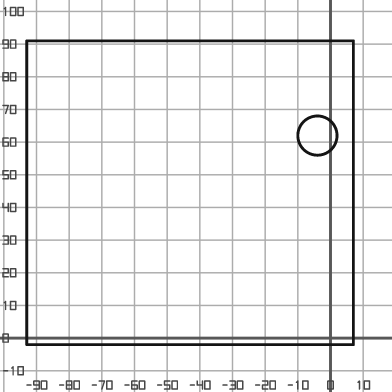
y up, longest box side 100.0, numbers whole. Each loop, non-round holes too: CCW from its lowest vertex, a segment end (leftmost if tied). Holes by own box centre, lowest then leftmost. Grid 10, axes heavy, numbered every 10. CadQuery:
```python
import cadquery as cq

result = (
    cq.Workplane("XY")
    .moveTo(-93.0, -2.0)
    .lineTo(7.0, -2.0)
    .lineTo(7.0, 91.0)
    .lineTo(-93.0, 91.0)
    .close()
    .moveTo(-4.0, 62.0)
    .circle(6.0)
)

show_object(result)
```